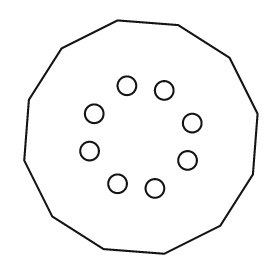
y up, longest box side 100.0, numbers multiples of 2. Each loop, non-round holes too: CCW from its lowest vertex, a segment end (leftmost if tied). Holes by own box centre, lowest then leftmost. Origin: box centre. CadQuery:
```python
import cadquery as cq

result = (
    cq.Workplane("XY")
    .moveTo(10.0, -50.0)
    .lineTo(34.0, -38.0)
    .lineTo(48.0, -16.0)
    .lineTo(50.0, 10.0)
    .lineTo(38.0, 34.0)
    .lineTo(16.0, 48.0)
    .lineTo(-10.0, 50.0)
    .lineTo(-34.0, 38.0)
    .lineTo(-48.0, 16.0)
    .lineTo(-50.0, -10.0)
    .lineTo(-38.0, -34.0)
    .lineTo(-16.0, -48.0)
    .close()
    .moveTo(6.0, -22.0)
    .circle(4.0)
    .moveTo(-10.0, -20.0)
    .circle(4.0)
    .moveTo(20.0, -10.0)
    .circle(4.0)
    .moveTo(-22.0, -6.0)
    .circle(4.0)
    .moveTo(22.0, 6.0)
    .circle(4.0)
    .moveTo(-20.0, 10.0)
    .circle(4.0)
    .moveTo(10.0, 20.0)
    .circle(4.0)
    .moveTo(-6.0, 22.0)
    .circle(4.0)
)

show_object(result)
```